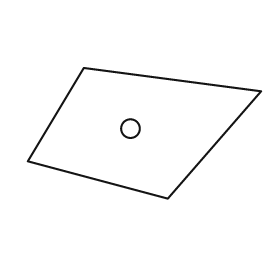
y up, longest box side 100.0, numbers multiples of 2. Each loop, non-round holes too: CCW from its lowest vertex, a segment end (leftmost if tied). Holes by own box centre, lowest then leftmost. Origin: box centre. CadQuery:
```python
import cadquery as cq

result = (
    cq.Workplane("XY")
    .moveTo(10.0, -28.0)
    .lineTo(50.0, 18.0)
    .lineTo(-26.0, 28.0)
    .lineTo(-50.0, -12.0)
    .close()
    .moveTo(-6.0, 2.0)
    .circle(4.0)
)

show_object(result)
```